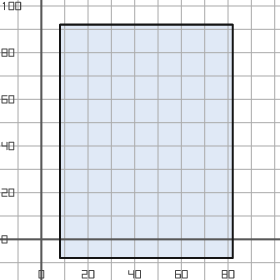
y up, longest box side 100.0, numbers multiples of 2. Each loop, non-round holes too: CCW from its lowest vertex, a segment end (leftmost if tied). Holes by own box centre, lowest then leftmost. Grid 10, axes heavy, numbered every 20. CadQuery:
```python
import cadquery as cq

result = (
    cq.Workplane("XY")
    .moveTo(8.0, -8.0)
    .lineTo(82.0, -8.0)
    .lineTo(82.0, 92.0)
    .lineTo(8.0, 92.0)
    .close()
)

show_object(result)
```